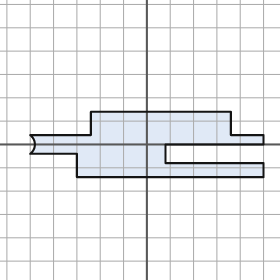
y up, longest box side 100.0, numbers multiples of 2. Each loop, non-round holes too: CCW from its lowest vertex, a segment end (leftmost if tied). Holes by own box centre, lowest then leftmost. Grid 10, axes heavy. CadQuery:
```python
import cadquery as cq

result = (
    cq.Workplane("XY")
    .moveTo(-30.0, -14.0)
    .lineTo(50.0, -14.0)
    .lineTo(50.0, -8.0)
    .lineTo(8.0, -8.0)
    .lineTo(8.0, 0.0)
    .lineTo(50.0, 0.0)
    .lineTo(50.0, 4.0)
    .lineTo(36.0, 4.0)
    .lineTo(36.0, 14.0)
    .lineTo(-24.0, 14.0)
    .lineTo(-24.0, 4.0)
    .lineTo(-50.0, 4.0)
    .threePointArc((-48.0, 0.0), (-50.0, -4.0))
    .lineTo(-30.0, -4.0)
    .close()
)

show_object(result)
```